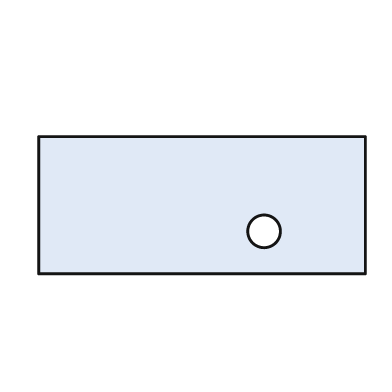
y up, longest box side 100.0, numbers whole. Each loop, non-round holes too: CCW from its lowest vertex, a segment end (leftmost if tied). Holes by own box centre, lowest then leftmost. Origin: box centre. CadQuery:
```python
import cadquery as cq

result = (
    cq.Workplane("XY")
    .moveTo(-50.0, -21.0)
    .lineTo(50.0, -21.0)
    .lineTo(50.0, 21.0)
    .lineTo(-50.0, 21.0)
    .close()
    .moveTo(19.0, -8.0)
    .circle(5.0)
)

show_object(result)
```